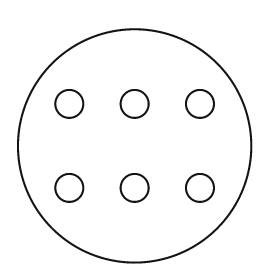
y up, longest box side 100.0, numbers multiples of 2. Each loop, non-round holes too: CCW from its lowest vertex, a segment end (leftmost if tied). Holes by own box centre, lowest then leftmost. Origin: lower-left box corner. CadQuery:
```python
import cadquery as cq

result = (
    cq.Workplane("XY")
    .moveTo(50.0, 50.0)
    .circle(50.0)
    .moveTo(22.0, 32.0)
    .circle(6.0)
    .moveTo(50.0, 32.0)
    .circle(6.0)
    .moveTo(78.0, 32.0)
    .circle(6.0)
    .moveTo(22.0, 68.0)
    .circle(6.0)
    .moveTo(50.0, 68.0)
    .circle(6.0)
    .moveTo(78.0, 68.0)
    .circle(6.0)
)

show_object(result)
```